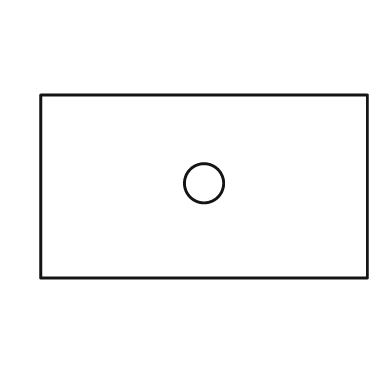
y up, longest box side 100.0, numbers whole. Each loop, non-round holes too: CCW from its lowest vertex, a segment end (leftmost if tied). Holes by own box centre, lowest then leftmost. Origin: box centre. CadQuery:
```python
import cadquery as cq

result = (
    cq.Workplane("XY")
    .moveTo(-50.0, -28.0)
    .lineTo(50.0, -28.0)
    .lineTo(50.0, 28.0)
    .lineTo(-50.0, 28.0)
    .close()
    .moveTo(0.0, 1.0)
    .circle(6.0)
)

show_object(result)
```